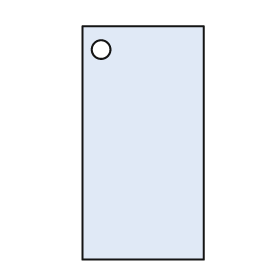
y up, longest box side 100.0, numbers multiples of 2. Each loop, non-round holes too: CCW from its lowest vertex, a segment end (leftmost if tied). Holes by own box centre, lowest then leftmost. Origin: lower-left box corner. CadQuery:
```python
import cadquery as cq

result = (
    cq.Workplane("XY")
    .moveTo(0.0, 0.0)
    .lineTo(52.0, 0.0)
    .lineTo(52.0, 100.0)
    .lineTo(0.0, 100.0)
    .close()
    .moveTo(8.0, 90.0)
    .circle(4.0)
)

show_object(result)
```